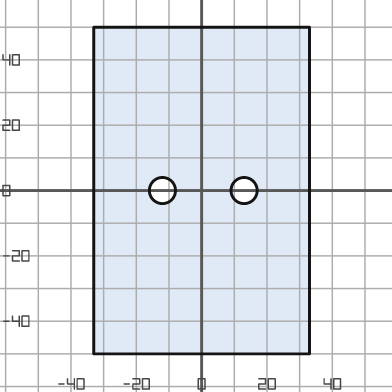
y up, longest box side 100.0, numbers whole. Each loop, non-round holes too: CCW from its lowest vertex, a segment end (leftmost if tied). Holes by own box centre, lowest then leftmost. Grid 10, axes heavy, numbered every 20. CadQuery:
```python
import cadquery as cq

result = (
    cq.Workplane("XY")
    .moveTo(-33.0, -50.0)
    .lineTo(33.0, -50.0)
    .lineTo(33.0, 50.0)
    .lineTo(-33.0, 50.0)
    .close()
    .moveTo(-12.0, 0.0)
    .circle(4.0)
    .moveTo(13.0, 0.0)
    .circle(4.0)
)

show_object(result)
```